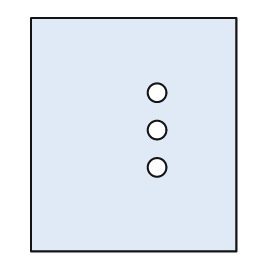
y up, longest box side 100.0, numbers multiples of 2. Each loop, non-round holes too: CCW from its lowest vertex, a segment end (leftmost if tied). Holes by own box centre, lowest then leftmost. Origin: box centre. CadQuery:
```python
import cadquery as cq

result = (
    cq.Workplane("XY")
    .moveTo(-44.0, -50.0)
    .lineTo(44.0, -50.0)
    .lineTo(44.0, 50.0)
    .lineTo(-44.0, 50.0)
    .close()
    .moveTo(10.0, -14.0)
    .circle(4.0)
    .moveTo(10.0, 2.0)
    .circle(4.0)
    .moveTo(10.0, 18.0)
    .circle(4.0)
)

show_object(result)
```